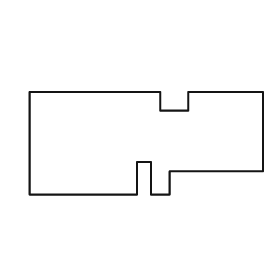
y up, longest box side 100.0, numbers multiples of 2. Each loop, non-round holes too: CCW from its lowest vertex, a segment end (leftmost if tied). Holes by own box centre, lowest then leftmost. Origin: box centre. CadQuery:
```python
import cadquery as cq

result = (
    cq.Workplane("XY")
    .moveTo(-50.0, -22.0)
    .lineTo(-4.0, -22.0)
    .lineTo(-4.0, -8.0)
    .lineTo(2.0, -8.0)
    .lineTo(2.0, -22.0)
    .lineTo(10.0, -22.0)
    .lineTo(10.0, -12.0)
    .lineTo(50.0, -12.0)
    .lineTo(50.0, 22.0)
    .lineTo(18.0, 22.0)
    .lineTo(18.0, 14.0)
    .lineTo(6.0, 14.0)
    .lineTo(6.0, 22.0)
    .lineTo(-50.0, 22.0)
    .close()
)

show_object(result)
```